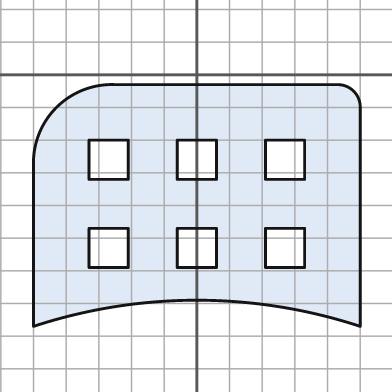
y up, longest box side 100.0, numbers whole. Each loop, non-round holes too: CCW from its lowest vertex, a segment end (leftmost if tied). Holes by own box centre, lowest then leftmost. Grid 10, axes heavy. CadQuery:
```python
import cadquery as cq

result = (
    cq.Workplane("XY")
    .moveTo(-50.0, -77.0)
    .threePointArc((0.0, -69.0), (50.0, -77.0))
    .lineTo(50.0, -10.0)
    .threePointArc((48.0, -5.0), (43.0, -3.0))
    .lineTo(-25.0, -3.0)
    .threePointArc((-43.0, -10.0), (-50.0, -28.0))
    .close()
    .moveTo(-33.0, -59.0)
    .lineTo(-21.0, -59.0)
    .lineTo(-21.0, -47.0)
    .lineTo(-33.0, -47.0)
    .close()
    .moveTo(-6.0, -59.0)
    .lineTo(6.0, -59.0)
    .lineTo(6.0, -47.0)
    .lineTo(-6.0, -47.0)
    .close()
    .moveTo(21.0, -59.0)
    .lineTo(33.0, -59.0)
    .lineTo(33.0, -47.0)
    .lineTo(21.0, -47.0)
    .close()
    .moveTo(-33.0, -32.0)
    .lineTo(-21.0, -32.0)
    .lineTo(-21.0, -20.0)
    .lineTo(-33.0, -20.0)
    .close()
    .moveTo(-6.0, -32.0)
    .lineTo(6.0, -32.0)
    .lineTo(6.0, -20.0)
    .lineTo(-6.0, -20.0)
    .close()
    .moveTo(21.0, -32.0)
    .lineTo(33.0, -32.0)
    .lineTo(33.0, -20.0)
    .lineTo(21.0, -20.0)
    .close()
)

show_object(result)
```